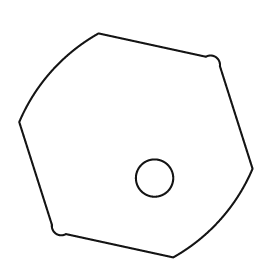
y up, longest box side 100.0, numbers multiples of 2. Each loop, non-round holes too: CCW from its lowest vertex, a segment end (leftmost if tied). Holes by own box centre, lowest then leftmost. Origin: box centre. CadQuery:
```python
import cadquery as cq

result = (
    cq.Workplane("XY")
    .moveTo(16.0, -48.0)
    .threePointArc((36.0, -32.0), (50.0, -10.0))
    .lineTo(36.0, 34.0)
    .threePointArc((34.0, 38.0), (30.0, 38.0))
    .lineTo(-16.0, 48.0)
    .threePointArc((-36.0, 32.0), (-50.0, 10.0))
    .lineTo(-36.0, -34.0)
    .threePointArc((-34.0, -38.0), (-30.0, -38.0))
    .close()
    .moveTo(8.0, -14.0)
    .circle(8.0)
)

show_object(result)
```